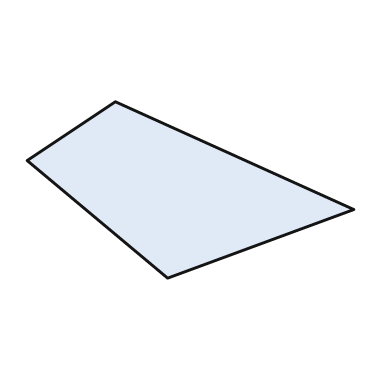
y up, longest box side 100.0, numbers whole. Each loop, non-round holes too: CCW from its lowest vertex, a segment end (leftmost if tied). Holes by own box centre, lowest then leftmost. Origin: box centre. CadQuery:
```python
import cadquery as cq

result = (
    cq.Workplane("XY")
    .moveTo(-7.0, -27.0)
    .lineTo(50.0, -6.0)
    .lineTo(-23.0, 27.0)
    .lineTo(-50.0, 9.0)
    .close()
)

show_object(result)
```